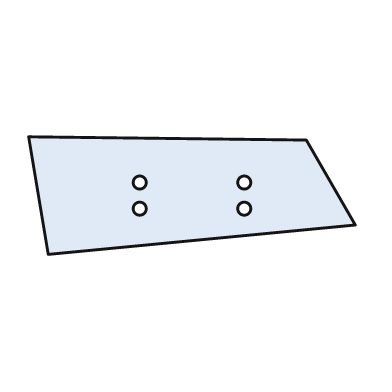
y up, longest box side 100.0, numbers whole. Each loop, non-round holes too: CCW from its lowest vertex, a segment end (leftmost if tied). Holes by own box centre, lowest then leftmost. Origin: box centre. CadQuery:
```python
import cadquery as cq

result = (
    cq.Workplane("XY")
    .moveTo(-44.0, -18.0)
    .lineTo(50.0, -9.0)
    .lineTo(35.0, 17.0)
    .lineTo(-50.0, 18.0)
    .close()
    .moveTo(-16.0, -4.0)
    .circle(2.0)
    .moveTo(16.0, -4.0)
    .circle(2.0)
    .moveTo(-16.0, 4.0)
    .circle(2.0)
    .moveTo(16.0, 4.0)
    .circle(2.0)
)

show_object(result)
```